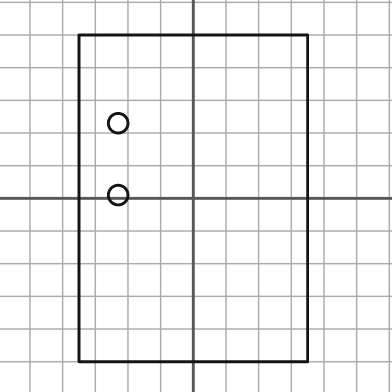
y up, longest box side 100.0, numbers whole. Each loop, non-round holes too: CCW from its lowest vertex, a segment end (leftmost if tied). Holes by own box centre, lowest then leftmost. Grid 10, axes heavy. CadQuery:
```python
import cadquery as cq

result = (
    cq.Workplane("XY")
    .moveTo(-35.0, -50.0)
    .lineTo(35.0, -50.0)
    .lineTo(35.0, 50.0)
    .lineTo(-35.0, 50.0)
    .close()
    .moveTo(-23.0, 1.0)
    .circle(3.0)
    .moveTo(-23.0, 23.0)
    .circle(3.0)
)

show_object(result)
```